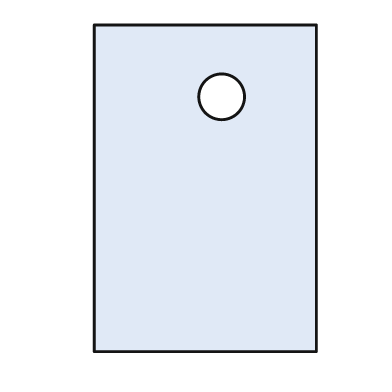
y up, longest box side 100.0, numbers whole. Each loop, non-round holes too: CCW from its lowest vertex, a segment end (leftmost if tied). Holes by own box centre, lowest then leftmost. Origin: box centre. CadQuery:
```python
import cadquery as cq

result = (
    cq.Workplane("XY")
    .moveTo(-34.0, -50.0)
    .lineTo(34.0, -50.0)
    .lineTo(34.0, 50.0)
    .lineTo(-34.0, 50.0)
    .close()
    .moveTo(5.0, 28.0)
    .circle(7.0)
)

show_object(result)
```